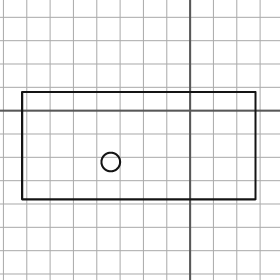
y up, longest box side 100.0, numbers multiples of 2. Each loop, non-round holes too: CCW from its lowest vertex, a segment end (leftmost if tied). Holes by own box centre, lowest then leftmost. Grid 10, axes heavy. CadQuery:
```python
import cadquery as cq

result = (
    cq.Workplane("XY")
    .moveTo(-72.0, -38.0)
    .lineTo(28.0, -38.0)
    .lineTo(28.0, 8.0)
    .lineTo(-72.0, 8.0)
    .close()
    .moveTo(-34.0, -22.0)
    .circle(4.0)
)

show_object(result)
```